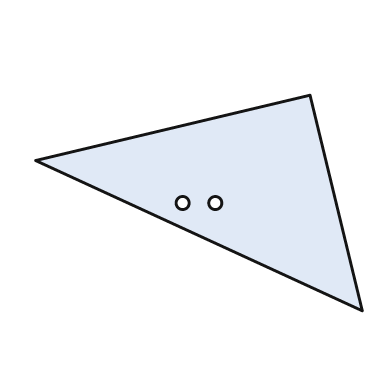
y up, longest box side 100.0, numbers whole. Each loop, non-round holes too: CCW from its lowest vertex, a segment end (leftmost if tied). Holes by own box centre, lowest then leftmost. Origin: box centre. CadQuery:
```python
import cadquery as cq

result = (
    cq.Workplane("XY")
    .moveTo(50.0, -33.0)
    .lineTo(34.0, 33.0)
    .lineTo(-50.0, 13.0)
    .close()
    .moveTo(-5.0, 0.0)
    .circle(2.0)
    .moveTo(5.0, 0.0)
    .circle(2.0)
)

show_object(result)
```